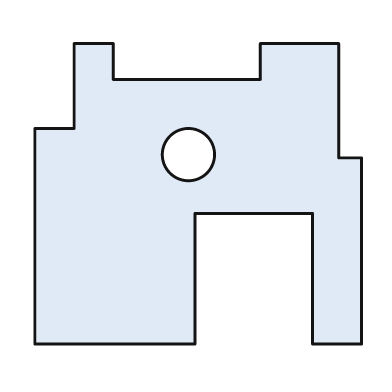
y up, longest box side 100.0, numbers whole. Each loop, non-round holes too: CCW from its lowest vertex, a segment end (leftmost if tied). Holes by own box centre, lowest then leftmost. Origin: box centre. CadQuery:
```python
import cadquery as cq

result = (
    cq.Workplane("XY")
    .moveTo(-50.0, -46.0)
    .lineTo(-1.0, -46.0)
    .lineTo(-1.0, -6.0)
    .lineTo(35.0, -6.0)
    .lineTo(35.0, -46.0)
    .lineTo(50.0, -46.0)
    .lineTo(50.0, 11.0)
    .lineTo(43.0, 11.0)
    .lineTo(43.0, 46.0)
    .lineTo(19.0, 46.0)
    .lineTo(19.0, 35.0)
    .lineTo(-26.0, 35.0)
    .lineTo(-26.0, 46.0)
    .lineTo(-38.0, 46.0)
    .lineTo(-38.0, 20.0)
    .lineTo(-50.0, 20.0)
    .close()
    .moveTo(-3.0, 12.0)
    .circle(8.0)
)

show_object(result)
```